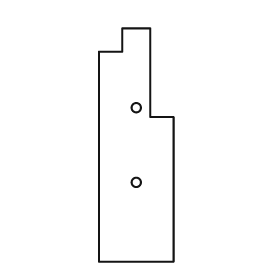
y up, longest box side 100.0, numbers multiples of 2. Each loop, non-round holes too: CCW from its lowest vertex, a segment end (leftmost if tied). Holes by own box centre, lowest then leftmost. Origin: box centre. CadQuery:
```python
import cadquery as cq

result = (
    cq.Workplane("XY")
    .moveTo(-16.0, -50.0)
    .lineTo(16.0, -50.0)
    .lineTo(16.0, 12.0)
    .lineTo(6.0, 12.0)
    .lineTo(6.0, 50.0)
    .lineTo(-6.0, 50.0)
    .lineTo(-6.0, 40.0)
    .lineTo(-16.0, 40.0)
    .close()
    .moveTo(0.0, -16.0)
    .circle(2.0)
    .moveTo(0.0, 16.0)
    .circle(2.0)
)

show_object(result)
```